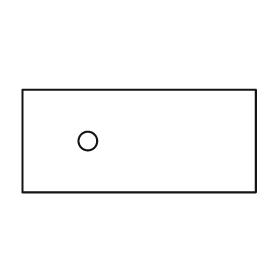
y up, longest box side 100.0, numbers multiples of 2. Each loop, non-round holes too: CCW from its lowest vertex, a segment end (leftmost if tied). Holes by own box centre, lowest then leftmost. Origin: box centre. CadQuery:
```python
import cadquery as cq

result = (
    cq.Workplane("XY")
    .moveTo(-50.0, -22.0)
    .lineTo(50.0, -22.0)
    .lineTo(50.0, 22.0)
    .lineTo(-50.0, 22.0)
    .close()
    .moveTo(-22.0, 0.0)
    .circle(4.0)
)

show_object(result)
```